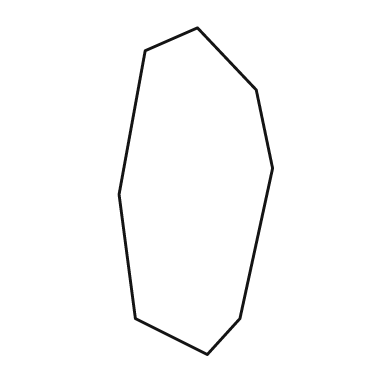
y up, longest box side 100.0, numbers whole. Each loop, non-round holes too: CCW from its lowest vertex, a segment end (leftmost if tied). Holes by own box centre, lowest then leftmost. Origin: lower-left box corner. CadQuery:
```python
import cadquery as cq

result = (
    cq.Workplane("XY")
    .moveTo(27.0, 0.0)
    .lineTo(37.0, 11.0)
    .lineTo(47.0, 57.0)
    .lineTo(42.0, 81.0)
    .lineTo(24.0, 100.0)
    .lineTo(8.0, 93.0)
    .lineTo(0.0, 49.0)
    .lineTo(5.0, 11.0)
    .close()
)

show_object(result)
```